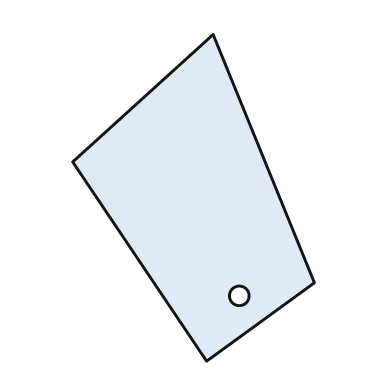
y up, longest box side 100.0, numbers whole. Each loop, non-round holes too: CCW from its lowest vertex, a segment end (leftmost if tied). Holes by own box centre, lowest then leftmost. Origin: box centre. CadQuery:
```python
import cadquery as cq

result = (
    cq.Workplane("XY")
    .moveTo(4.0, -50.0)
    .lineTo(37.0, -26.0)
    .lineTo(6.0, 50.0)
    .lineTo(-37.0, 11.0)
    .close()
    .moveTo(14.0, -30.0)
    .circle(3.0)
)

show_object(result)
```